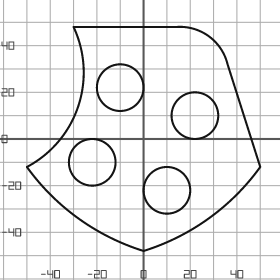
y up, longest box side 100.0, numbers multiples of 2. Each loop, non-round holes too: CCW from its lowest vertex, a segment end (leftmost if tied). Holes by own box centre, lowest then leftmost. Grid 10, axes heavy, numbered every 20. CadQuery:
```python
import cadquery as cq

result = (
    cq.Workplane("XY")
    .moveTo(0.0, -48.0)
    .threePointArc((28.0, -34.0), (50.0, -12.0))
    .lineTo(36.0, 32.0)
    .threePointArc((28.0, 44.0), (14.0, 48.0))
    .lineTo(-30.0, 48.0)
    .threePointArc((-28.0, 14.0), (-50.0, -12.0))
    .threePointArc((-28.0, -34.0), (0.0, -48.0))
    .close()
    .moveTo(10.0, -22.0)
    .circle(10.0)
    .moveTo(-22.0, -10.0)
    .circle(10.0)
    .moveTo(22.0, 10.0)
    .circle(10.0)
    .moveTo(-10.0, 22.0)
    .circle(10.0)
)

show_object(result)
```